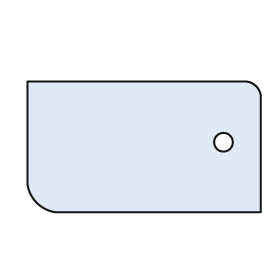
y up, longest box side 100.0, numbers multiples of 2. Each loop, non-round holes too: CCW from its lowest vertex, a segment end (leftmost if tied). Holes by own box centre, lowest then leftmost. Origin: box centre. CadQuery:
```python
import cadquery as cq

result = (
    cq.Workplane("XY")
    .moveTo(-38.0, -28.0)
    .lineTo(50.0, -28.0)
    .lineTo(50.0, 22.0)
    .threePointArc((48.0, 26.0), (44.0, 28.0))
    .lineTo(-50.0, 28.0)
    .lineTo(-50.0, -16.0)
    .threePointArc((-46.0, -24.0), (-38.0, -28.0))
    .close()
    .moveTo(34.0, 2.0)
    .circle(4.0)
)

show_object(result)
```